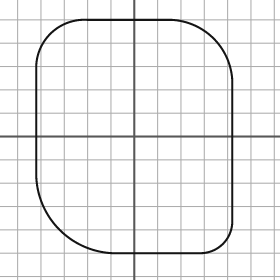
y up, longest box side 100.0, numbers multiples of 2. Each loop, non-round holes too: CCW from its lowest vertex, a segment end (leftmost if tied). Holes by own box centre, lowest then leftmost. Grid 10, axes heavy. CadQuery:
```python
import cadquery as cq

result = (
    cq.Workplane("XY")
    .moveTo(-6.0, -50.0)
    .lineTo(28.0, -50.0)
    .threePointArc((38.0, -46.0), (42.0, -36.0))
    .lineTo(42.0, 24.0)
    .threePointArc((34.0, 42.0), (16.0, 50.0))
    .lineTo(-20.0, 50.0)
    .threePointArc((-36.0, 44.0), (-42.0, 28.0))
    .lineTo(-42.0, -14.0)
    .threePointArc((-32.0, -40.0), (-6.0, -50.0))
    .close()
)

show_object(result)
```